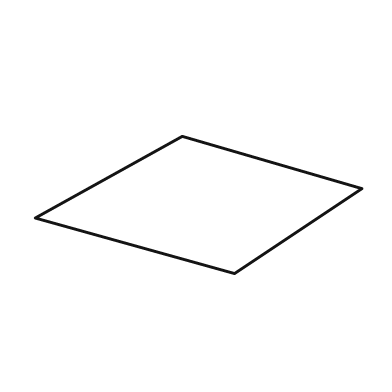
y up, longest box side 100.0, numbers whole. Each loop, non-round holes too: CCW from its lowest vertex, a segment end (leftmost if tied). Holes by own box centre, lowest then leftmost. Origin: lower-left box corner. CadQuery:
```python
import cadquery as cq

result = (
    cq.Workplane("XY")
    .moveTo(61.0, 0.0)
    .lineTo(100.0, 26.0)
    .lineTo(45.0, 42.0)
    .lineTo(0.0, 17.0)
    .close()
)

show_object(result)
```